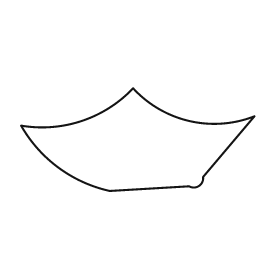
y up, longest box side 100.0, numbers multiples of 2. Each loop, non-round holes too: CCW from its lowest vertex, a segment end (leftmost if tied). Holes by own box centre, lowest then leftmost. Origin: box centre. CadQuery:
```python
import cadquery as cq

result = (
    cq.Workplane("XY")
    .moveTo(-12.0, -22.0)
    .lineTo(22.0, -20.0)
    .threePointArc((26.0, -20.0), (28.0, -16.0))
    .lineTo(50.0, 10.0)
    .threePointArc((22.0, 8.0), (-2.0, 22.0))
    .threePointArc((-24.0, 8.0), (-50.0, 6.0))
    .threePointArc((-34.0, -12.0), (-12.0, -22.0))
    .close()
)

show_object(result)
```